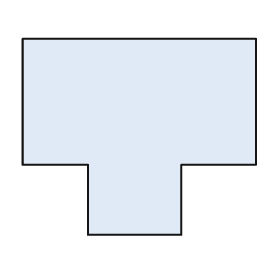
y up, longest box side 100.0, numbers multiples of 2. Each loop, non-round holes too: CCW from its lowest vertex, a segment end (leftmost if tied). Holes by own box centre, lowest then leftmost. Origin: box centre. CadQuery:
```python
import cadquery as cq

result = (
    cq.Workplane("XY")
    .moveTo(-22.0, -42.0)
    .lineTo(18.0, -42.0)
    .lineTo(18.0, -12.0)
    .lineTo(50.0, -12.0)
    .lineTo(50.0, 42.0)
    .lineTo(-50.0, 42.0)
    .lineTo(-50.0, -12.0)
    .lineTo(-22.0, -12.0)
    .close()
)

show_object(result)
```